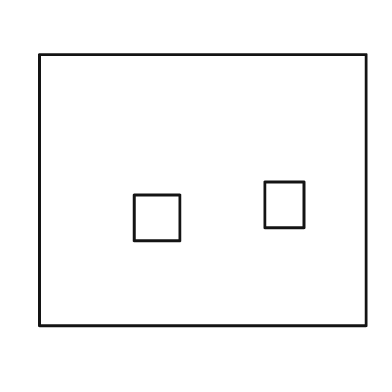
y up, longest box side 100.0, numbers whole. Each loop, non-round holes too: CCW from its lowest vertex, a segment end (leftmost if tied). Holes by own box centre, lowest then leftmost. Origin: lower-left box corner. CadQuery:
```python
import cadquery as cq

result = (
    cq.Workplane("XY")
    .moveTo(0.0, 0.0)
    .lineTo(100.0, 0.0)
    .lineTo(100.0, 83.0)
    .lineTo(0.0, 83.0)
    .close()
    .moveTo(29.0, 26.0)
    .lineTo(43.0, 26.0)
    .lineTo(43.0, 40.0)
    .lineTo(29.0, 40.0)
    .close()
    .moveTo(69.0, 30.0)
    .lineTo(81.0, 30.0)
    .lineTo(81.0, 44.0)
    .lineTo(69.0, 44.0)
    .close()
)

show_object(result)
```